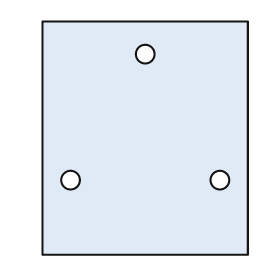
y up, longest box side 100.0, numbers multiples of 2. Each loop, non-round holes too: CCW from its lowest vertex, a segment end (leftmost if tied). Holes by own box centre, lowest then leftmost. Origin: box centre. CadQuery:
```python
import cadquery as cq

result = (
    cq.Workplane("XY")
    .moveTo(-44.0, -50.0)
    .lineTo(44.0, -50.0)
    .lineTo(44.0, 50.0)
    .lineTo(-44.0, 50.0)
    .close()
    .moveTo(-32.0, -18.0)
    .circle(4.0)
    .moveTo(32.0, -18.0)
    .circle(4.0)
    .moveTo(0.0, 36.0)
    .circle(4.0)
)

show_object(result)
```